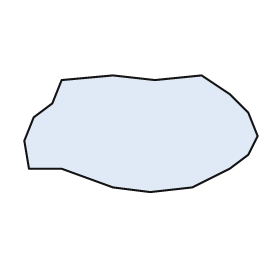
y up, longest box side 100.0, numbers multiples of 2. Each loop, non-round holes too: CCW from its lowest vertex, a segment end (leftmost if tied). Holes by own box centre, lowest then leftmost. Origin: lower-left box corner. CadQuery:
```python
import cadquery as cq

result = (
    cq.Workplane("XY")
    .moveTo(54.0, 0.0)
    .lineTo(72.0, 2.0)
    .lineTo(88.0, 10.0)
    .lineTo(96.0, 16.0)
    .lineTo(100.0, 24.0)
    .lineTo(96.0, 34.0)
    .lineTo(88.0, 42.0)
    .lineTo(76.0, 50.0)
    .lineTo(56.0, 48.0)
    .lineTo(38.0, 50.0)
    .lineTo(16.0, 48.0)
    .lineTo(12.0, 38.0)
    .lineTo(4.0, 32.0)
    .lineTo(0.0, 22.0)
    .lineTo(2.0, 10.0)
    .lineTo(16.0, 10.0)
    .lineTo(38.0, 2.0)
    .close()
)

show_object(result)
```